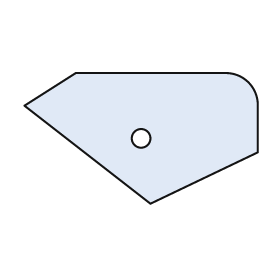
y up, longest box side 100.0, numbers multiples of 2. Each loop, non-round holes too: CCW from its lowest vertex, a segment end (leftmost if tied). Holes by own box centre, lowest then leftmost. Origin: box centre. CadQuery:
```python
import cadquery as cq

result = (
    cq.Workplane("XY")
    .moveTo(4.0, -28.0)
    .lineTo(50.0, -6.0)
    .lineTo(50.0, 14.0)
    .threePointArc((46.0, 24.0), (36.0, 28.0))
    .lineTo(-28.0, 28.0)
    .lineTo(-50.0, 14.0)
    .close()
    .moveTo(0.0, 0.0)
    .circle(4.0)
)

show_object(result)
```